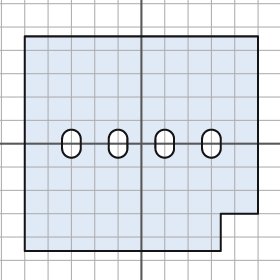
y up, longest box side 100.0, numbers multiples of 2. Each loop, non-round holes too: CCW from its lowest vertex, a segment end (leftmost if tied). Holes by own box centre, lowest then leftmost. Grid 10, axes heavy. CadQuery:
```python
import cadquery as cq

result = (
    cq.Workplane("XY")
    .moveTo(-50.0, -46.0)
    .lineTo(34.0, -46.0)
    .lineTo(34.0, -30.0)
    .lineTo(50.0, -30.0)
    .lineTo(50.0, 46.0)
    .lineTo(-50.0, 46.0)
    .close()
    .moveTo(-34.0, -2.0)
    .threePointArc((-30.0, -6.0), (-26.0, -2.0))
    .lineTo(-26.0, 2.0)
    .threePointArc((-30.0, 6.0), (-34.0, 2.0))
    .close()
    .moveTo(-14.0, -2.0)
    .threePointArc((-10.0, -6.0), (-6.0, -2.0))
    .lineTo(-6.0, 2.0)
    .threePointArc((-10.0, 6.0), (-14.0, 2.0))
    .close()
    .moveTo(6.0, -2.0)
    .threePointArc((10.0, -6.0), (14.0, -2.0))
    .lineTo(14.0, 2.0)
    .threePointArc((10.0, 6.0), (6.0, 2.0))
    .close()
    .moveTo(26.0, -2.0)
    .threePointArc((30.0, -6.0), (34.0, -2.0))
    .lineTo(34.0, 2.0)
    .threePointArc((30.0, 6.0), (26.0, 2.0))
    .close()
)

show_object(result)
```